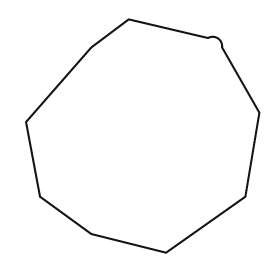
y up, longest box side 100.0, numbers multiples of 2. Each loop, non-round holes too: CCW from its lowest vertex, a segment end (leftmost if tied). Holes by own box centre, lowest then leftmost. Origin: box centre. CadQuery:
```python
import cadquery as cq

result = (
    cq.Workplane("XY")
    .moveTo(10.0, -50.0)
    .lineTo(44.0, -26.0)
    .lineTo(50.0, 10.0)
    .lineTo(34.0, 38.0)
    .threePointArc((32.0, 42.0), (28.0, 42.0))
    .lineTo(-6.0, 50.0)
    .lineTo(-22.0, 38.0)
    .lineTo(-50.0, 6.0)
    .lineTo(-44.0, -26.0)
    .lineTo(-22.0, -42.0)
    .close()
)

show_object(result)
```